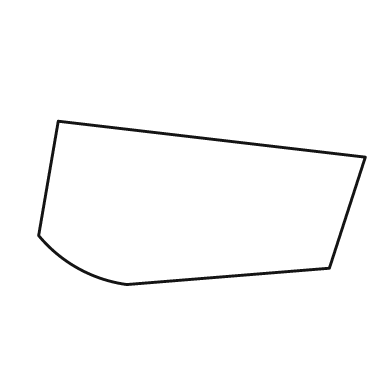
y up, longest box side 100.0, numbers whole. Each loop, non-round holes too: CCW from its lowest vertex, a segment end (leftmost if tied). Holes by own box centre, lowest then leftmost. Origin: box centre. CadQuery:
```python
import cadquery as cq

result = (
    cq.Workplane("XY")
    .moveTo(-23.0, -25.0)
    .lineTo(39.0, -20.0)
    .lineTo(50.0, 14.0)
    .lineTo(-44.0, 25.0)
    .lineTo(-50.0, -10.0)
    .threePointArc((-38.0, -20.0), (-23.0, -25.0))
    .close()
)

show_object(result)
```